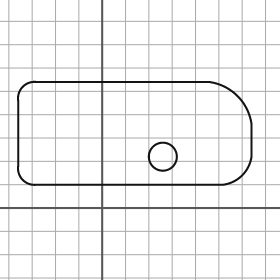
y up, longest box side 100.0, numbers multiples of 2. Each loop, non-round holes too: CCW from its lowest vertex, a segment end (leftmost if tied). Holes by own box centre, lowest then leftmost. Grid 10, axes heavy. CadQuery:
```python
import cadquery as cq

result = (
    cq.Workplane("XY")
    .moveTo(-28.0, 10.0)
    .lineTo(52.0, 10.0)
    .threePointArc((60.0, 14.0), (64.0, 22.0))
    .lineTo(64.0, 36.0)
    .threePointArc((58.0, 48.0), (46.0, 54.0))
    .lineTo(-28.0, 54.0)
    .threePointArc((-34.0, 52.0), (-36.0, 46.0))
    .lineTo(-36.0, 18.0)
    .threePointArc((-34.0, 12.0), (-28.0, 10.0))
    .close()
    .moveTo(26.0, 22.0)
    .circle(6.0)
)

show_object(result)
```